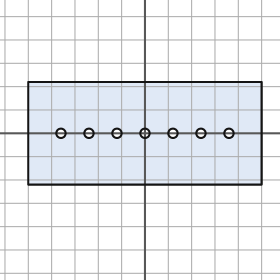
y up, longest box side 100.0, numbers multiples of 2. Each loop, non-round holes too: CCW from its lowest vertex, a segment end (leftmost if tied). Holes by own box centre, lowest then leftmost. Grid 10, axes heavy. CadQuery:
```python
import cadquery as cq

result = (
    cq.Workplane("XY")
    .moveTo(-50.0, -22.0)
    .lineTo(50.0, -22.0)
    .lineTo(50.0, 22.0)
    .lineTo(-50.0, 22.0)
    .close()
    .moveTo(-36.0, 0.0)
    .circle(2.0)
    .moveTo(-24.0, 0.0)
    .circle(2.0)
    .moveTo(-12.0, 0.0)
    .circle(2.0)
    .moveTo(0.0, 0.0)
    .circle(2.0)
    .moveTo(12.0, 0.0)
    .circle(2.0)
    .moveTo(24.0, 0.0)
    .circle(2.0)
    .moveTo(36.0, 0.0)
    .circle(2.0)
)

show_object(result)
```